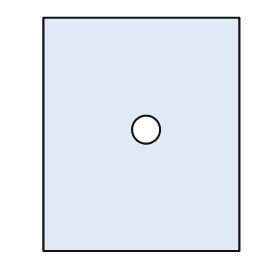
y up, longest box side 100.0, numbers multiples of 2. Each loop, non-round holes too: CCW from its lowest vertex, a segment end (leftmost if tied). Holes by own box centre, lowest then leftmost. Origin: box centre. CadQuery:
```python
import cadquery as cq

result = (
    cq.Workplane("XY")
    .moveTo(-42.0, -50.0)
    .lineTo(42.0, -50.0)
    .lineTo(42.0, 50.0)
    .lineTo(-42.0, 50.0)
    .close()
    .moveTo(2.0, 2.0)
    .circle(6.0)
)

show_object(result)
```